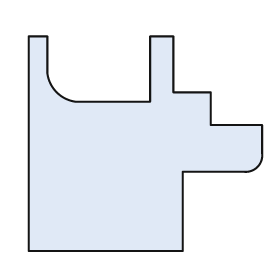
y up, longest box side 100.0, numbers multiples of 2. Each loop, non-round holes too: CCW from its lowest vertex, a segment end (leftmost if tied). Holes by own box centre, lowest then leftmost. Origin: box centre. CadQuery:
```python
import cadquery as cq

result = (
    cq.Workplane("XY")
    .moveTo(-50.0, -46.0)
    .lineTo(16.0, -46.0)
    .lineTo(16.0, -12.0)
    .lineTo(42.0, -12.0)
    .threePointArc((48.0, -10.0), (50.0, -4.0))
    .lineTo(50.0, 8.0)
    .lineTo(28.0, 8.0)
    .lineTo(28.0, 22.0)
    .lineTo(12.0, 22.0)
    .lineTo(12.0, 46.0)
    .lineTo(2.0, 46.0)
    .lineTo(2.0, 18.0)
    .lineTo(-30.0, 18.0)
    .threePointArc((-38.0, 22.0), (-42.0, 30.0))
    .lineTo(-42.0, 46.0)
    .lineTo(-50.0, 46.0)
    .close()
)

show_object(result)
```